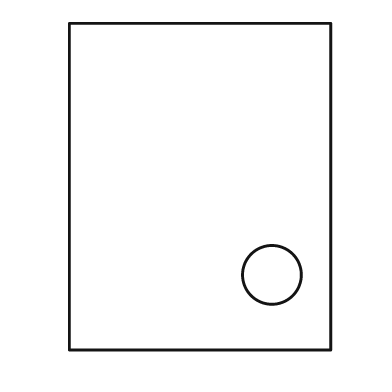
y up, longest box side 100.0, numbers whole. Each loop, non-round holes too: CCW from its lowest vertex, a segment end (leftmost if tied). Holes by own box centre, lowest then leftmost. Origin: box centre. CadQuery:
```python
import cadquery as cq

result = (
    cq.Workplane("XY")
    .moveTo(-40.0, -50.0)
    .lineTo(40.0, -50.0)
    .lineTo(40.0, 50.0)
    .lineTo(-40.0, 50.0)
    .close()
    .moveTo(22.0, -27.0)
    .circle(9.0)
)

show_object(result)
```